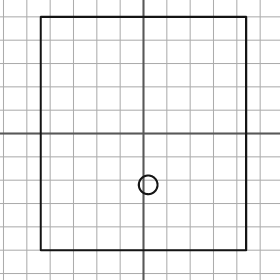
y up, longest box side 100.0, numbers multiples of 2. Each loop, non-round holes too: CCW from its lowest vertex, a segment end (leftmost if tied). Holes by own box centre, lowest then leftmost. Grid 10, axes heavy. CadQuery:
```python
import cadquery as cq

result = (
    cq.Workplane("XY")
    .moveTo(-44.0, -50.0)
    .lineTo(44.0, -50.0)
    .lineTo(44.0, 50.0)
    .lineTo(-44.0, 50.0)
    .close()
    .moveTo(2.0, -22.0)
    .circle(4.0)
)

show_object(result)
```